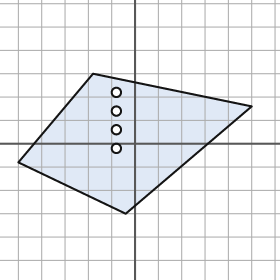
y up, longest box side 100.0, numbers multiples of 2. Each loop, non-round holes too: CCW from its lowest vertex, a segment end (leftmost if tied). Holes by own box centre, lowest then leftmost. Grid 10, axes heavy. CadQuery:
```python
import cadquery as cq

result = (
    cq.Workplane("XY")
    .moveTo(-4.0, -30.0)
    .lineTo(50.0, 16.0)
    .lineTo(-18.0, 30.0)
    .lineTo(-50.0, -8.0)
    .close()
    .moveTo(-8.0, -2.0)
    .circle(2.0)
    .moveTo(-8.0, 6.0)
    .circle(2.0)
    .moveTo(-8.0, 14.0)
    .circle(2.0)
    .moveTo(-8.0, 22.0)
    .circle(2.0)
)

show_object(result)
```